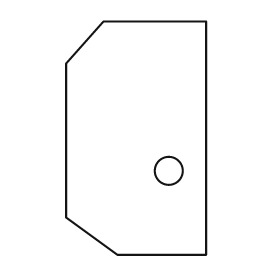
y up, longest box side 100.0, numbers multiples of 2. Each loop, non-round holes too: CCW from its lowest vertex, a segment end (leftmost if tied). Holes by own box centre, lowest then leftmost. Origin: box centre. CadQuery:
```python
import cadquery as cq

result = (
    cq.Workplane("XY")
    .moveTo(-8.0, -50.0)
    .lineTo(30.0, -50.0)
    .lineTo(30.0, 50.0)
    .lineTo(-14.0, 50.0)
    .lineTo(-30.0, 32.0)
    .lineTo(-30.0, -34.0)
    .close()
    .moveTo(14.0, -14.0)
    .circle(6.0)
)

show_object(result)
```